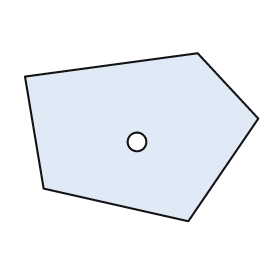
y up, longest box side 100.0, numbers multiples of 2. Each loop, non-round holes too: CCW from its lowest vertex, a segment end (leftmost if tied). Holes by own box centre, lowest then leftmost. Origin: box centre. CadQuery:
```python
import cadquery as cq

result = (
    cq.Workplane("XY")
    .moveTo(20.0, -36.0)
    .lineTo(50.0, 8.0)
    .lineTo(24.0, 36.0)
    .lineTo(-50.0, 26.0)
    .lineTo(-42.0, -22.0)
    .close()
    .moveTo(-2.0, -2.0)
    .circle(4.0)
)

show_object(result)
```